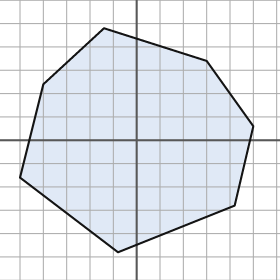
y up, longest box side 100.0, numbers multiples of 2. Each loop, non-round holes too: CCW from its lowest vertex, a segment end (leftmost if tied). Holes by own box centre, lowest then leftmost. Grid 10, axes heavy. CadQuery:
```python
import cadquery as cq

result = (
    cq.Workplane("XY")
    .moveTo(-8.0, -48.0)
    .lineTo(42.0, -28.0)
    .lineTo(50.0, 6.0)
    .lineTo(30.0, 34.0)
    .lineTo(-14.0, 48.0)
    .lineTo(-40.0, 24.0)
    .lineTo(-50.0, -16.0)
    .close()
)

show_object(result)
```